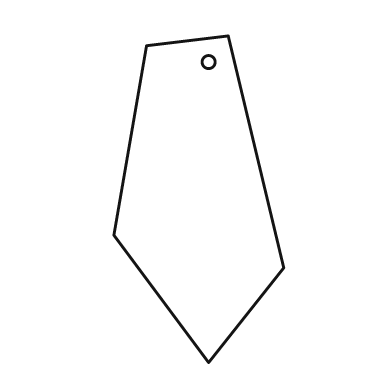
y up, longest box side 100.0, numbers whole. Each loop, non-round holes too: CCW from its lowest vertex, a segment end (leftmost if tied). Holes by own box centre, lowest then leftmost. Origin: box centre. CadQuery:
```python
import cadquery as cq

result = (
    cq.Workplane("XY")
    .moveTo(3.0, -50.0)
    .lineTo(26.0, -21.0)
    .lineTo(9.0, 50.0)
    .lineTo(-16.0, 47.0)
    .lineTo(-26.0, -11.0)
    .close()
    .moveTo(3.0, 42.0)
    .circle(2.0)
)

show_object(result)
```